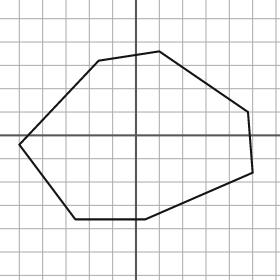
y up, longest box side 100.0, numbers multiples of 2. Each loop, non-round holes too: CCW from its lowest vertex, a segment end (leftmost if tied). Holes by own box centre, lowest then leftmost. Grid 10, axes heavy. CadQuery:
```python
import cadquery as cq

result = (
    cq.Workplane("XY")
    .moveTo(-26.0, -36.0)
    .lineTo(4.0, -36.0)
    .lineTo(50.0, -16.0)
    .lineTo(48.0, 10.0)
    .lineTo(10.0, 36.0)
    .lineTo(-16.0, 32.0)
    .lineTo(-50.0, -4.0)
    .close()
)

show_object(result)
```